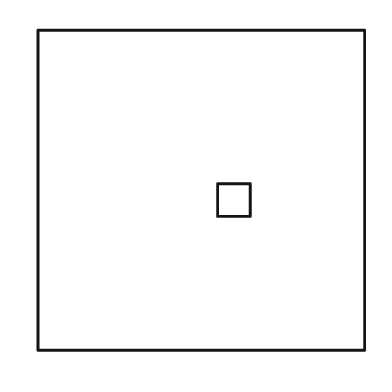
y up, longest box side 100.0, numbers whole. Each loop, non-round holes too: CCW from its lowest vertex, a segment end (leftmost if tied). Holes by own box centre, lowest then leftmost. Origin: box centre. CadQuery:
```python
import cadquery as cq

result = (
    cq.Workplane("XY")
    .moveTo(-50.0, -49.0)
    .lineTo(50.0, -49.0)
    .lineTo(50.0, 49.0)
    .lineTo(-50.0, 49.0)
    .close()
    .moveTo(5.0, -8.0)
    .lineTo(15.0, -8.0)
    .lineTo(15.0, 2.0)
    .lineTo(5.0, 2.0)
    .close()
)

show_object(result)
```